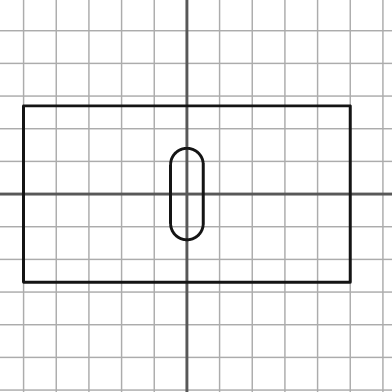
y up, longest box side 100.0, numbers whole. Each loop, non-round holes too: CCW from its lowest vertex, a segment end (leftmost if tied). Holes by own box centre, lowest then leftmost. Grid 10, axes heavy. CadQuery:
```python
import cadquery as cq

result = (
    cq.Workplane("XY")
    .moveTo(-50.0, -27.0)
    .lineTo(50.0, -27.0)
    .lineTo(50.0, 27.0)
    .lineTo(-50.0, 27.0)
    .close()
    .moveTo(-5.0, -9.0)
    .threePointArc((0.0, -14.0), (5.0, -9.0))
    .lineTo(5.0, 9.0)
    .threePointArc((0.0, 14.0), (-5.0, 9.0))
    .close()
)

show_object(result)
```